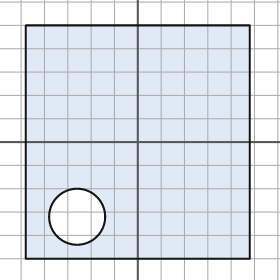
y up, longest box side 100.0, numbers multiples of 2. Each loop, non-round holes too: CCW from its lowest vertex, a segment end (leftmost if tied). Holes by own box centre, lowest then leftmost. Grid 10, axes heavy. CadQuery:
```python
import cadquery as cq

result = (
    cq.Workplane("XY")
    .moveTo(-48.0, -50.0)
    .lineTo(48.0, -50.0)
    .lineTo(48.0, 50.0)
    .lineTo(-48.0, 50.0)
    .close()
    .moveTo(-26.0, -32.0)
    .circle(12.0)
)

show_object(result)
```